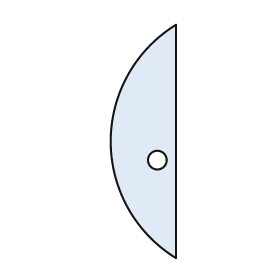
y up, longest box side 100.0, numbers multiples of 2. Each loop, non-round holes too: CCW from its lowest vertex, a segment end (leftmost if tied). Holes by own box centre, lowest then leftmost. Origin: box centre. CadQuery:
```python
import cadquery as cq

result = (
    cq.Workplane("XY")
    .moveTo(14.0, -50.0)
    .lineTo(14.0, 50.0)
    .threePointArc((-14.0, 0.0), (14.0, -50.0))
    .close()
    .moveTo(6.0, -8.0)
    .circle(4.0)
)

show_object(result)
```